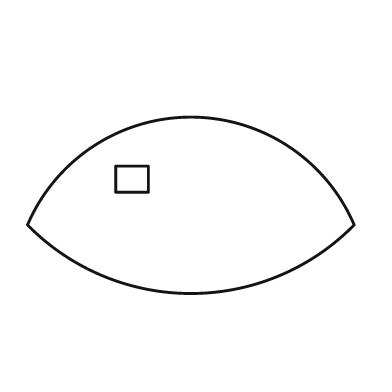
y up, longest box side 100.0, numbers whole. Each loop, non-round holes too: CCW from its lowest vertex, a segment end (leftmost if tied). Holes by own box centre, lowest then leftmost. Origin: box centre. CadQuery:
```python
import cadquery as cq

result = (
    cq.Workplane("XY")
    .moveTo(-50.0, -6.0)
    .threePointArc((0.0, -27.0), (50.0, -6.0))
    .threePointArc((0.0, 27.0), (-50.0, -6.0))
    .close()
    .moveTo(-23.0, 4.0)
    .lineTo(-13.0, 4.0)
    .lineTo(-13.0, 12.0)
    .lineTo(-23.0, 12.0)
    .close()
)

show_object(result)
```